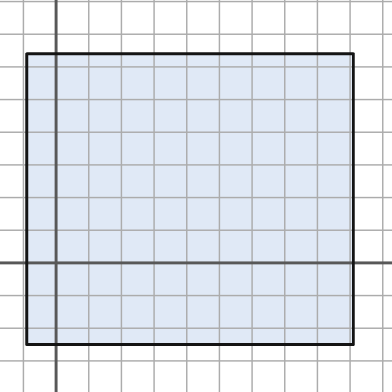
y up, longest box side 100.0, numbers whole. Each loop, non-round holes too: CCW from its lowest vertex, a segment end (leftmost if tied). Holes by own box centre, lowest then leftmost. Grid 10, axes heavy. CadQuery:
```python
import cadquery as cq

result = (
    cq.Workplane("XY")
    .moveTo(-9.0, -25.0)
    .lineTo(91.0, -25.0)
    .lineTo(91.0, 64.0)
    .lineTo(-9.0, 64.0)
    .close()
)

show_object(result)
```